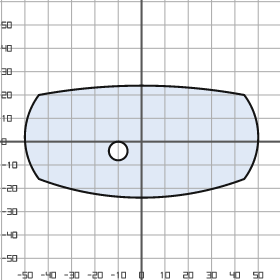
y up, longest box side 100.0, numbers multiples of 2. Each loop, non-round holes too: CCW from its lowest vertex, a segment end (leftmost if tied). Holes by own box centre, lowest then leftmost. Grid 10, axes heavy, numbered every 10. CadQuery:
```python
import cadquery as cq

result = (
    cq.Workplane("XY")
    .moveTo(-44.0, -16.0)
    .threePointArc((0.0, -24.0), (44.0, -16.0))
    .threePointArc((50.0, 2.0), (44.0, 20.0))
    .threePointArc((0.0, 24.0), (-44.0, 20.0))
    .threePointArc((-50.0, 2.0), (-44.0, -16.0))
    .close()
    .moveTo(-10.0, -4.0)
    .circle(4.0)
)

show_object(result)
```